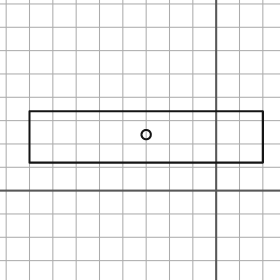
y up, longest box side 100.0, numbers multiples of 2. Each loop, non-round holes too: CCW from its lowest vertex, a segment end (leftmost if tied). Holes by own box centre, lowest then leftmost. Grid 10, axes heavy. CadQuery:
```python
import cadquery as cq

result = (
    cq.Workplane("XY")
    .moveTo(-80.0, 12.0)
    .lineTo(20.0, 12.0)
    .lineTo(20.0, 34.0)
    .lineTo(-80.0, 34.0)
    .close()
    .moveTo(-30.0, 24.0)
    .circle(2.0)
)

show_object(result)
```